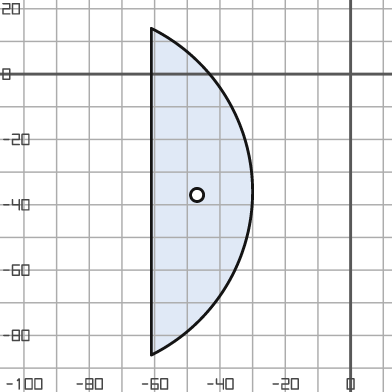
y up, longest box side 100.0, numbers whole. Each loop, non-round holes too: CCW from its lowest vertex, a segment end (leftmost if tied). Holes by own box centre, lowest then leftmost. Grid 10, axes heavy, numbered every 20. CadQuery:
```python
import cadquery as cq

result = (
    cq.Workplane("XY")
    .moveTo(-61.0, -86.0)
    .threePointArc((-30.0, -36.0), (-61.0, 14.0))
    .close()
    .moveTo(-47.0, -37.0)
    .circle(2.0)
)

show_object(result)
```